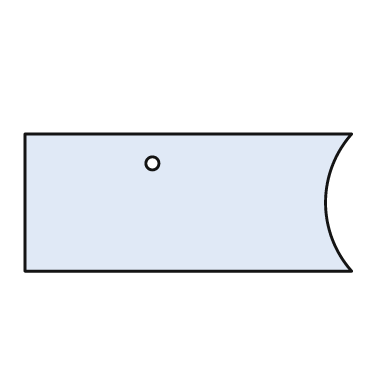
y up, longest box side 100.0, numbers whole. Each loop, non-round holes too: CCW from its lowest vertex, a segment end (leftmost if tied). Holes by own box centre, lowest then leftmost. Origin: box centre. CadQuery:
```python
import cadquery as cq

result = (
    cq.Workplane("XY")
    .moveTo(-50.0, -21.0)
    .lineTo(50.0, -21.0)
    .threePointArc((42.0, 0.0), (50.0, 21.0))
    .lineTo(-50.0, 21.0)
    .close()
    .moveTo(-11.0, 12.0)
    .circle(2.0)
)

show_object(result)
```